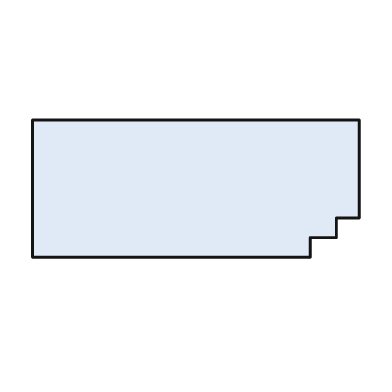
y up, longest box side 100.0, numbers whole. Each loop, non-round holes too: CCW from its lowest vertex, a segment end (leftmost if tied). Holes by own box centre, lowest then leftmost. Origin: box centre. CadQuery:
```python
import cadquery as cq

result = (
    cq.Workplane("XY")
    .moveTo(-50.0, -21.0)
    .lineTo(35.0, -21.0)
    .lineTo(35.0, -15.0)
    .lineTo(43.0, -15.0)
    .lineTo(43.0, -9.0)
    .lineTo(50.0, -9.0)
    .lineTo(50.0, 21.0)
    .lineTo(-50.0, 21.0)
    .close()
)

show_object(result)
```